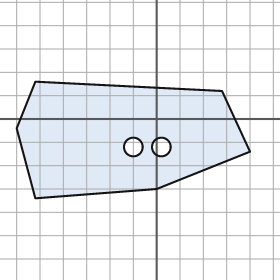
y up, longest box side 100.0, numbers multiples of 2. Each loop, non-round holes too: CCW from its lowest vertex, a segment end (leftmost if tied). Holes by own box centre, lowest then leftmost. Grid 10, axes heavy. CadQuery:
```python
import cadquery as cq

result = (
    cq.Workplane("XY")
    .moveTo(-52.0, -34.0)
    .lineTo(0.0, -30.0)
    .lineTo(40.0, -14.0)
    .lineTo(28.0, 12.0)
    .lineTo(-52.0, 16.0)
    .lineTo(-60.0, -4.0)
    .close()
    .moveTo(-10.0, -12.0)
    .circle(4.0)
    .moveTo(2.0, -12.0)
    .circle(4.0)
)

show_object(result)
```